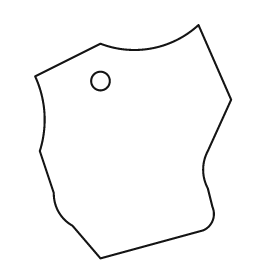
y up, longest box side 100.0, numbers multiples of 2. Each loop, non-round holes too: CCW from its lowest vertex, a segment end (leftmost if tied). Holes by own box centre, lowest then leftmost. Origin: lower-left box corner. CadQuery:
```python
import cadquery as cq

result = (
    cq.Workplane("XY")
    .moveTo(28.0, 0.0)
    .lineTo(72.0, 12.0)
    .threePointArc((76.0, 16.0), (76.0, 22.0))
    .lineTo(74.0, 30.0)
    .threePointArc((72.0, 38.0), (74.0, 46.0))
    .lineTo(84.0, 68.0)
    .lineTo(70.0, 100.0)
    .threePointArc((50.0, 90.0), (28.0, 92.0))
    .lineTo(0.0, 78.0)
    .threePointArc((4.0, 62.0), (2.0, 46.0))
    .lineTo(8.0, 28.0)
    .threePointArc((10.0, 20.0), (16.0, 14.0))
    .close()
    .moveTo(28.0, 76.0)
    .circle(4.0)
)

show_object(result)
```